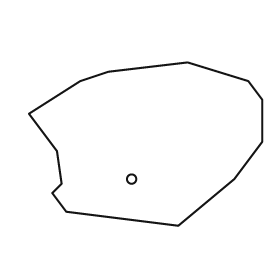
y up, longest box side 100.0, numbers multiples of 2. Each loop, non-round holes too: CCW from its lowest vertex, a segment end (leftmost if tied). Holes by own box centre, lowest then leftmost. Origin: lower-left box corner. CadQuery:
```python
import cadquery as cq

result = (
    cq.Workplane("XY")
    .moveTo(64.0, 0.0)
    .lineTo(88.0, 20.0)
    .lineTo(100.0, 36.0)
    .lineTo(100.0, 54.0)
    .lineTo(94.0, 62.0)
    .lineTo(68.0, 70.0)
    .lineTo(34.0, 66.0)
    .lineTo(22.0, 62.0)
    .lineTo(0.0, 48.0)
    .lineTo(12.0, 32.0)
    .lineTo(14.0, 18.0)
    .lineTo(10.0, 14.0)
    .lineTo(16.0, 6.0)
    .close()
    .moveTo(44.0, 20.0)
    .circle(2.0)
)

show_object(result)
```